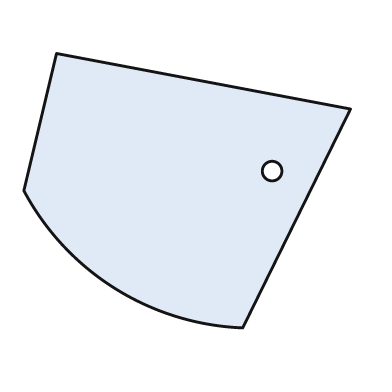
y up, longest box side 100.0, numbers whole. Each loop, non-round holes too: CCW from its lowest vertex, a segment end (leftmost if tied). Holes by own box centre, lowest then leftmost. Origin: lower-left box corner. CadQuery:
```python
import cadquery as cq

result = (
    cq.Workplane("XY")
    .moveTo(67.0, 0.0)
    .lineTo(100.0, 67.0)
    .lineTo(10.0, 84.0)
    .lineTo(0.0, 42.0)
    .threePointArc((28.0, 12.0), (67.0, 0.0))
    .close()
    .moveTo(76.0, 48.0)
    .circle(3.0)
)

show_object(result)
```